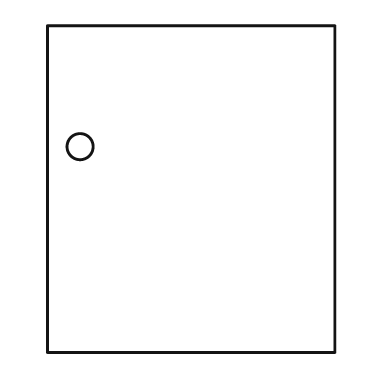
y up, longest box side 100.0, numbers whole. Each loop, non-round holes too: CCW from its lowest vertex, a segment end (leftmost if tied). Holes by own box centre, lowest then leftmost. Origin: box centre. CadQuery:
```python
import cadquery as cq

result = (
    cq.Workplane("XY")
    .moveTo(-44.0, -50.0)
    .lineTo(44.0, -50.0)
    .lineTo(44.0, 50.0)
    .lineTo(-44.0, 50.0)
    .close()
    .moveTo(-34.0, 13.0)
    .circle(4.0)
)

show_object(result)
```